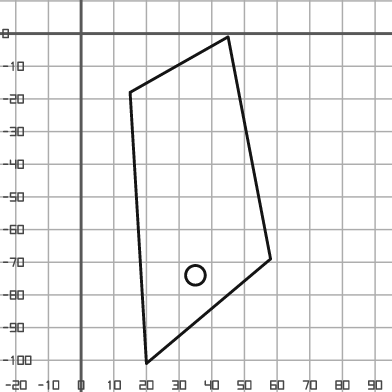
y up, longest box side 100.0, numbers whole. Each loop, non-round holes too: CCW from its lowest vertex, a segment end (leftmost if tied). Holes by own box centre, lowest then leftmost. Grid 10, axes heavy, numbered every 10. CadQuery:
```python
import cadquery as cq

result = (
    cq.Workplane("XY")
    .moveTo(20.0, -101.0)
    .lineTo(58.0, -69.0)
    .lineTo(45.0, -1.0)
    .lineTo(15.0, -18.0)
    .close()
    .moveTo(35.0, -74.0)
    .circle(3.0)
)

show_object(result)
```